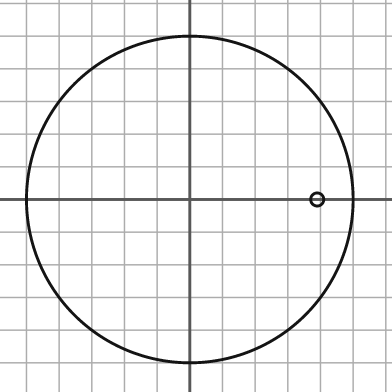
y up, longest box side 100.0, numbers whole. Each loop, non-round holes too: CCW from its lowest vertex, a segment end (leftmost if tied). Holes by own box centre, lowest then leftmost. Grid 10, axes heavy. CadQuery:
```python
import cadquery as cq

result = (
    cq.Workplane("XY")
    .moveTo(0.0, 0.0)
    .circle(50.0)
    .moveTo(39.0, 0.0)
    .circle(2.0)
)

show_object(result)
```